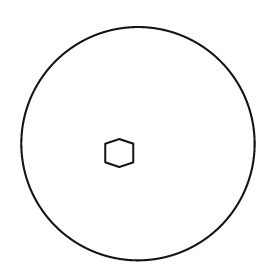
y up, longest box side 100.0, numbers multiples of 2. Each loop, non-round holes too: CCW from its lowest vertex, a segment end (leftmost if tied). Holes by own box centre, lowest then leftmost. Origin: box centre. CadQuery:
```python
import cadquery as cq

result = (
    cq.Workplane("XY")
    .moveTo(0.0, 0.0)
    .circle(50.0)
    .moveTo(-8.0, -10.0)
    .lineTo(-2.0, -8.0)
    .lineTo(-2.0, 0.0)
    .lineTo(-8.0, 2.0)
    .lineTo(-14.0, 0.0)
    .lineTo(-14.0, -8.0)
    .close()
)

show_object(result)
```